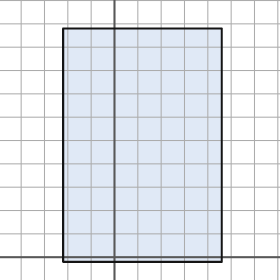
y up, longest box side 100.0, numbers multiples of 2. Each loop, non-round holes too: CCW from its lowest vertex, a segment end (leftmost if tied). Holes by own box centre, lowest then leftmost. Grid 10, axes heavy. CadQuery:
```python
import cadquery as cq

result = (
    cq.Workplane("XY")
    .moveTo(-22.0, -2.0)
    .lineTo(46.0, -2.0)
    .lineTo(46.0, 98.0)
    .lineTo(-22.0, 98.0)
    .close()
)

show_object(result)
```